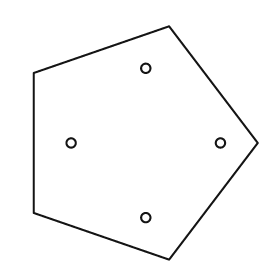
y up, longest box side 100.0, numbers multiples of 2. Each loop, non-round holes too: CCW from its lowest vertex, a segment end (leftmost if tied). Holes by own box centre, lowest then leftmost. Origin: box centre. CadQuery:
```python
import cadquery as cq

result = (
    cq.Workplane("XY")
    .moveTo(10.0, -50.0)
    .lineTo(48.0, 0.0)
    .lineTo(10.0, 50.0)
    .lineTo(-48.0, 30.0)
    .lineTo(-48.0, -30.0)
    .close()
    .moveTo(0.0, -32.0)
    .circle(2.0)
    .moveTo(-32.0, 0.0)
    .circle(2.0)
    .moveTo(32.0, 0.0)
    .circle(2.0)
    .moveTo(0.0, 32.0)
    .circle(2.0)
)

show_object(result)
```